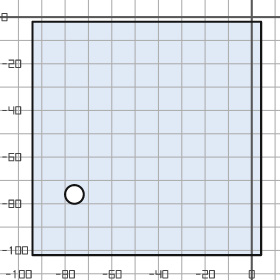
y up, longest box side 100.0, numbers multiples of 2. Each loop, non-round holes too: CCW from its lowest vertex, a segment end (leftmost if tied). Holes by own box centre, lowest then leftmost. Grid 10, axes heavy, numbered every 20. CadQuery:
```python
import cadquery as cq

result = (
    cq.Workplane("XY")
    .moveTo(-94.0, -102.0)
    .lineTo(4.0, -102.0)
    .lineTo(4.0, -2.0)
    .lineTo(-94.0, -2.0)
    .close()
    .moveTo(-76.0, -76.0)
    .circle(4.0)
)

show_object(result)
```